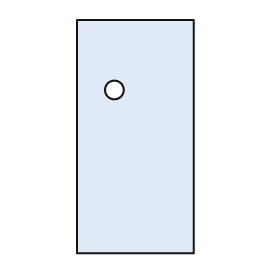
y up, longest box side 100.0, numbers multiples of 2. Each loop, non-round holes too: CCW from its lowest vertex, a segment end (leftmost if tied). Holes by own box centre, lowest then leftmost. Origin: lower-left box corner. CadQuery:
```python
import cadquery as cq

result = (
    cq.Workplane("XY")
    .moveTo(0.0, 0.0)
    .lineTo(50.0, 0.0)
    .lineTo(50.0, 100.0)
    .lineTo(0.0, 100.0)
    .close()
    .moveTo(16.0, 70.0)
    .circle(4.0)
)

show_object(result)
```